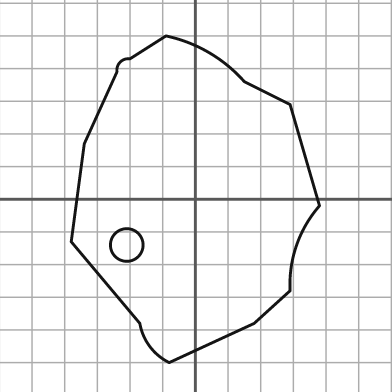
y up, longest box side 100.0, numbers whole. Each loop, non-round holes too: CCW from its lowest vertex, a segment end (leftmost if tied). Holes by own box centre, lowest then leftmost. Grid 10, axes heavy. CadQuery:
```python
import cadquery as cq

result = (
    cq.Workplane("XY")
    .moveTo(-8.0, -50.0)
    .lineTo(18.0, -38.0)
    .lineTo(29.0, -28.0)
    .threePointArc((31.0, -14.0), (38.0, -2.0))
    .lineTo(29.0, 29.0)
    .lineTo(15.0, 36.0)
    .threePointArc((4.0, 45.0), (-9.0, 50.0))
    .lineTo(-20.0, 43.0)
    .threePointArc((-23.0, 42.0), (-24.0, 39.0))
    .lineTo(-34.0, 17.0)
    .lineTo(-38.0, -13.0)
    .lineTo(-17.0, -38.0)
    .threePointArc((-14.0, -45.0), (-8.0, -50.0))
    .close()
    .moveTo(-21.0, -14.0)
    .circle(5.0)
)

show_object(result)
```